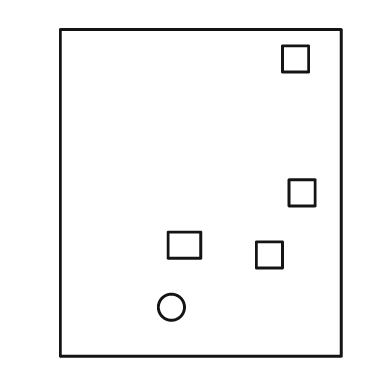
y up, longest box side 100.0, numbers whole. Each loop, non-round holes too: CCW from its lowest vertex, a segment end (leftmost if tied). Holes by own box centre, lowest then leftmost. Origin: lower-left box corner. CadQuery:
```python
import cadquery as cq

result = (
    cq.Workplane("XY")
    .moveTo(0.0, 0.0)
    .lineTo(86.0, 0.0)
    .lineTo(86.0, 100.0)
    .lineTo(0.0, 100.0)
    .close()
    .moveTo(34.0, 15.0)
    .circle(4.0)
    .moveTo(60.0, 27.0)
    .lineTo(68.0, 27.0)
    .lineTo(68.0, 35.0)
    .lineTo(60.0, 35.0)
    .close()
    .moveTo(33.0, 30.0)
    .lineTo(43.0, 30.0)
    .lineTo(43.0, 38.0)
    .lineTo(33.0, 38.0)
    .close()
    .moveTo(70.0, 46.0)
    .lineTo(78.0, 46.0)
    .lineTo(78.0, 54.0)
    .lineTo(70.0, 54.0)
    .close()
    .moveTo(68.0, 87.0)
    .lineTo(76.0, 87.0)
    .lineTo(76.0, 95.0)
    .lineTo(68.0, 95.0)
    .close()
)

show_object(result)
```